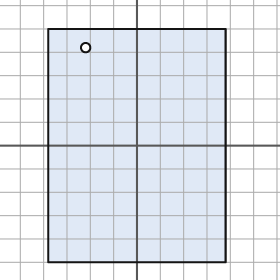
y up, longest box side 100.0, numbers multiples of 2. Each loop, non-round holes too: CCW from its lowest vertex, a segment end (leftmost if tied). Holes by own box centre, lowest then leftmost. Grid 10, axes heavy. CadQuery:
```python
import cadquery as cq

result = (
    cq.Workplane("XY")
    .moveTo(-38.0, -50.0)
    .lineTo(38.0, -50.0)
    .lineTo(38.0, 50.0)
    .lineTo(-38.0, 50.0)
    .close()
    .moveTo(-22.0, 42.0)
    .circle(2.0)
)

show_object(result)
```